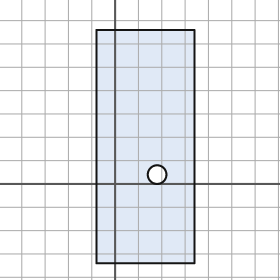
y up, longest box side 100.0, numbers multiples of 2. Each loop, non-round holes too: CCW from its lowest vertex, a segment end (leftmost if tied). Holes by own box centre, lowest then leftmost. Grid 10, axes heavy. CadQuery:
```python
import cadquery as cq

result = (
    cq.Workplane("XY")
    .moveTo(-8.0, -34.0)
    .lineTo(34.0, -34.0)
    .lineTo(34.0, 66.0)
    .lineTo(-8.0, 66.0)
    .close()
    .moveTo(18.0, 4.0)
    .circle(4.0)
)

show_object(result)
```